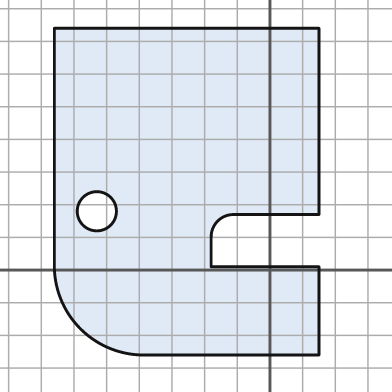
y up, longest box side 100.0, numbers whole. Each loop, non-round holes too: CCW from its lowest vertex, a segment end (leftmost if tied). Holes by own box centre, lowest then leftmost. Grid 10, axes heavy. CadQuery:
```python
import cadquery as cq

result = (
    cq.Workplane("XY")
    .moveTo(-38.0, -26.0)
    .lineTo(15.0, -26.0)
    .lineTo(15.0, 1.0)
    .lineTo(-18.0, 1.0)
    .lineTo(-18.0, 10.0)
    .threePointArc((-16.0, 15.0), (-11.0, 17.0))
    .lineTo(15.0, 17.0)
    .lineTo(15.0, 74.0)
    .lineTo(-66.0, 74.0)
    .lineTo(-66.0, 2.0)
    .threePointArc((-58.0, -18.0), (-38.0, -26.0))
    .close()
    .moveTo(-53.0, 18.0)
    .circle(6.0)
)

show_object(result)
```